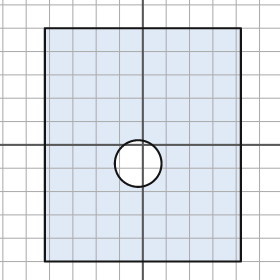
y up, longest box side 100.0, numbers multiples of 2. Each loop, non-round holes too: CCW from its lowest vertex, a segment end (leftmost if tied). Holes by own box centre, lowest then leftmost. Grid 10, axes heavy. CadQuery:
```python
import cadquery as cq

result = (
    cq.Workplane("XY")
    .moveTo(-42.0, -50.0)
    .lineTo(42.0, -50.0)
    .lineTo(42.0, 50.0)
    .lineTo(-42.0, 50.0)
    .close()
    .moveTo(-2.0, -8.0)
    .circle(10.0)
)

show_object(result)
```